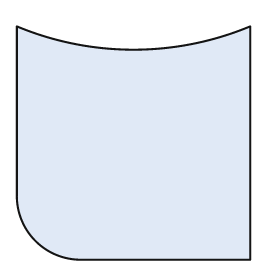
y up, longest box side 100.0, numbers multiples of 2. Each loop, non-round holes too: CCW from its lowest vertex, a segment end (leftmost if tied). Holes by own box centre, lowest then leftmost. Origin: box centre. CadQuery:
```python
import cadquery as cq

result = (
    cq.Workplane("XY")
    .moveTo(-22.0, -50.0)
    .lineTo(50.0, -50.0)
    .lineTo(50.0, 50.0)
    .threePointArc((0.0, 40.0), (-50.0, 50.0))
    .lineTo(-50.0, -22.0)
    .threePointArc((-42.0, -42.0), (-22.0, -50.0))
    .close()
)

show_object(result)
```